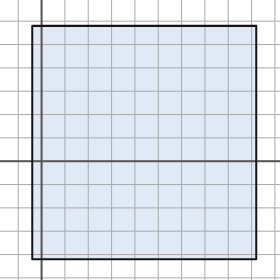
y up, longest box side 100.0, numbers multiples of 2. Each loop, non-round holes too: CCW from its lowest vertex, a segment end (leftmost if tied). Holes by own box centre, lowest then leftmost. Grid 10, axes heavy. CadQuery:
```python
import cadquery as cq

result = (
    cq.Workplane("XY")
    .moveTo(-4.0, -42.0)
    .lineTo(92.0, -42.0)
    .lineTo(92.0, 58.0)
    .lineTo(-4.0, 58.0)
    .close()
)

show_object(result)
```